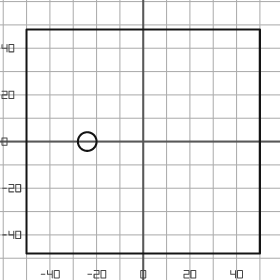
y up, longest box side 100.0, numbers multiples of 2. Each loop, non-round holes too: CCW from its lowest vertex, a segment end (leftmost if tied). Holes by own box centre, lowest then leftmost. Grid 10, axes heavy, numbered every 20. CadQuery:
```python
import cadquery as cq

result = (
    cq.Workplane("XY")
    .moveTo(-50.0, -48.0)
    .lineTo(50.0, -48.0)
    .lineTo(50.0, 48.0)
    .lineTo(-50.0, 48.0)
    .close()
    .moveTo(-24.0, 0.0)
    .circle(4.0)
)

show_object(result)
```